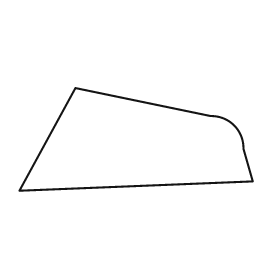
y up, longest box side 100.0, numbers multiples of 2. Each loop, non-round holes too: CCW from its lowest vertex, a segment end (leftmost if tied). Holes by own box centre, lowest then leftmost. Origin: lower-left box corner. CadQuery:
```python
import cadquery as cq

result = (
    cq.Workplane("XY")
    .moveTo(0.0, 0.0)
    .lineTo(100.0, 4.0)
    .lineTo(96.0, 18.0)
    .threePointArc((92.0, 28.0), (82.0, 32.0))
    .lineTo(24.0, 44.0)
    .close()
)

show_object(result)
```